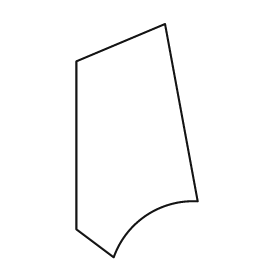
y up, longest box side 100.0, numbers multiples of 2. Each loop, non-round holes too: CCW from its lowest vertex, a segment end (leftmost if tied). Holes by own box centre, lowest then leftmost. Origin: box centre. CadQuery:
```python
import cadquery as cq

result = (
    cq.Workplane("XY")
    .moveTo(-10.0, -50.0)
    .threePointArc((4.0, -32.0), (26.0, -26.0))
    .lineTo(12.0, 50.0)
    .lineTo(-26.0, 34.0)
    .lineTo(-26.0, -38.0)
    .close()
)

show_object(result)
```